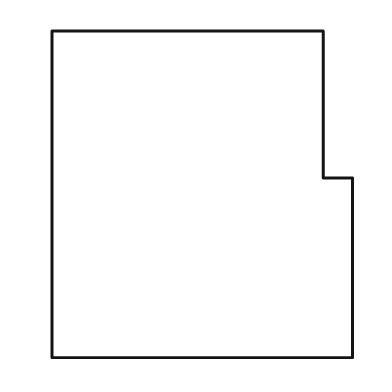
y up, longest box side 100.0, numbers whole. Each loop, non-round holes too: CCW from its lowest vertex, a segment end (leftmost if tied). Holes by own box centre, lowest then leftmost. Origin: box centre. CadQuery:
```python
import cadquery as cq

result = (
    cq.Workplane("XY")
    .moveTo(-46.0, -50.0)
    .lineTo(46.0, -50.0)
    .lineTo(46.0, 5.0)
    .lineTo(37.0, 5.0)
    .lineTo(37.0, 50.0)
    .lineTo(-46.0, 50.0)
    .close()
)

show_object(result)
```